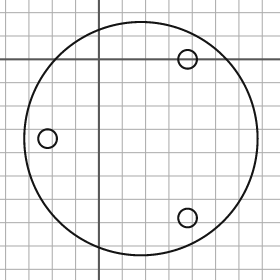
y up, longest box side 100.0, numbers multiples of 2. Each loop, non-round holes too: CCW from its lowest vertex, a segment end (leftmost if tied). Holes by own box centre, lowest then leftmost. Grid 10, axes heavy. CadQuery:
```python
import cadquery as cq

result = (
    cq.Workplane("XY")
    .moveTo(18.0, -34.0)
    .circle(50.0)
    .moveTo(38.0, -68.0)
    .circle(4.0)
    .moveTo(-22.0, -34.0)
    .circle(4.0)
    .moveTo(38.0, 0.0)
    .circle(4.0)
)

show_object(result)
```